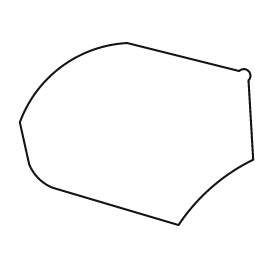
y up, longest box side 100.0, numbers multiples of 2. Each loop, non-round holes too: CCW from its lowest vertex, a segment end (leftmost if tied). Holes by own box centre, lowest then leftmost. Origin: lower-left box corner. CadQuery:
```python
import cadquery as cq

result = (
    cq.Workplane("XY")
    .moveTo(68.0, 0.0)
    .threePointArc((82.0, 16.0), (100.0, 28.0))
    .lineTo(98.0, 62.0)
    .threePointArc((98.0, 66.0), (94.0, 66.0))
    .lineTo(46.0, 78.0)
    .threePointArc((18.0, 68.0), (0.0, 44.0))
    .lineTo(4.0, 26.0)
    .threePointArc((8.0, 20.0), (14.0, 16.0))
    .close()
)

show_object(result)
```